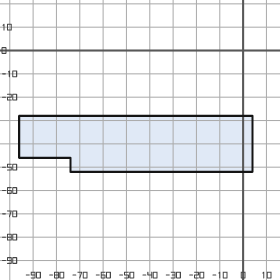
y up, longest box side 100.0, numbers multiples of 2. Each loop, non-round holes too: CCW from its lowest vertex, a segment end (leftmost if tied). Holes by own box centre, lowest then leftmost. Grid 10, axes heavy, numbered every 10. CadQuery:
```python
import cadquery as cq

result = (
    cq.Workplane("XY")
    .moveTo(-74.0, -52.0)
    .lineTo(4.0, -52.0)
    .lineTo(4.0, -28.0)
    .lineTo(-96.0, -28.0)
    .lineTo(-96.0, -46.0)
    .lineTo(-74.0, -46.0)
    .close()
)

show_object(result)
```